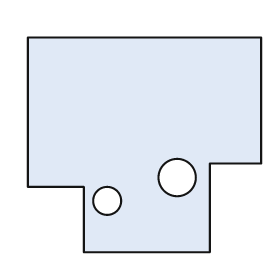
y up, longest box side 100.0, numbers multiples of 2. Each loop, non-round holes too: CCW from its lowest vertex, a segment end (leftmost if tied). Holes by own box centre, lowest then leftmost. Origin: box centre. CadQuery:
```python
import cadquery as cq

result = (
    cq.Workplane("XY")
    .moveTo(-26.0, -46.0)
    .lineTo(28.0, -46.0)
    .lineTo(28.0, -8.0)
    .lineTo(50.0, -8.0)
    .lineTo(50.0, 46.0)
    .lineTo(-50.0, 46.0)
    .lineTo(-50.0, -18.0)
    .lineTo(-26.0, -18.0)
    .close()
    .moveTo(-16.0, -24.0)
    .circle(6.0)
    .moveTo(14.0, -14.0)
    .circle(8.0)
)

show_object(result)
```